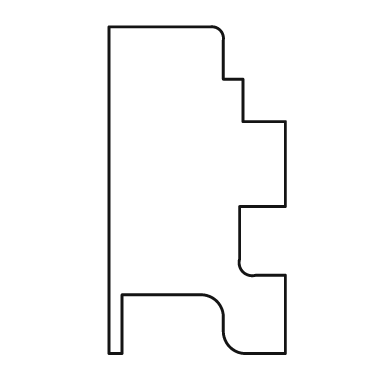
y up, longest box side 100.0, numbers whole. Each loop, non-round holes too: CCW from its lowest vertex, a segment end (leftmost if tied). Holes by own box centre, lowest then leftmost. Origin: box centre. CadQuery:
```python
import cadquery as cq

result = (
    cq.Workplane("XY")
    .moveTo(-27.0, -50.0)
    .lineTo(-23.0, -50.0)
    .lineTo(-23.0, -32.0)
    .lineTo(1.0, -32.0)
    .threePointArc((6.0, -34.0), (8.0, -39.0))
    .lineTo(8.0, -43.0)
    .threePointArc((10.0, -48.0), (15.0, -50.0))
    .lineTo(27.0, -50.0)
    .lineTo(27.0, -26.0)
    .lineTo(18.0, -26.0)
    .threePointArc((14.0, -25.0), (13.0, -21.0))
    .lineTo(13.0, -5.0)
    .lineTo(27.0, -5.0)
    .lineTo(27.0, 21.0)
    .lineTo(14.0, 21.0)
    .lineTo(14.0, 34.0)
    .lineTo(8.0, 34.0)
    .lineTo(8.0, 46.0)
    .threePointArc((7.0, 49.0), (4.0, 50.0))
    .lineTo(-27.0, 50.0)
    .close()
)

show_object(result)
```